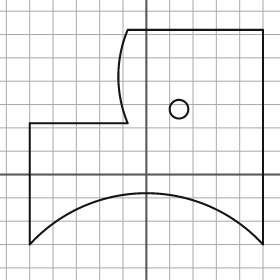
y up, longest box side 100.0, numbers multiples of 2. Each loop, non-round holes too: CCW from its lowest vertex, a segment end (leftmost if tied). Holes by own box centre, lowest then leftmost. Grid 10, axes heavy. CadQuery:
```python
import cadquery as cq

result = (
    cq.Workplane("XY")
    .moveTo(-50.0, -30.0)
    .threePointArc((0.0, -8.0), (50.0, -30.0))
    .lineTo(50.0, 62.0)
    .lineTo(-8.0, 62.0)
    .threePointArc((-12.0, 42.0), (-8.0, 22.0))
    .lineTo(-50.0, 22.0)
    .close()
    .moveTo(14.0, 28.0)
    .circle(4.0)
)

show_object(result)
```